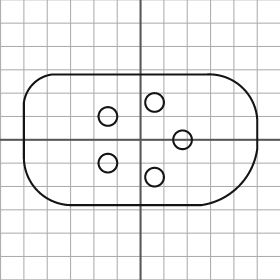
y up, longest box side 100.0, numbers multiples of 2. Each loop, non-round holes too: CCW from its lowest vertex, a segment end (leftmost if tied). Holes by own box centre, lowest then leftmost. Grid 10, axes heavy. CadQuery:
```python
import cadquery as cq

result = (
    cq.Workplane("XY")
    .moveTo(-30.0, -28.0)
    .lineTo(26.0, -28.0)
    .threePointArc((42.0, -20.0), (50.0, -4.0))
    .lineTo(50.0, 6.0)
    .threePointArc((44.0, 22.0), (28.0, 28.0))
    .lineTo(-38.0, 28.0)
    .threePointArc((-46.0, 24.0), (-50.0, 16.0))
    .lineTo(-50.0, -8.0)
    .threePointArc((-44.0, -22.0), (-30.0, -28.0))
    .close()
    .moveTo(6.0, -16.0)
    .circle(4.0)
    .moveTo(-14.0, -10.0)
    .circle(4.0)
    .moveTo(18.0, 0.0)
    .circle(4.0)
    .moveTo(-14.0, 10.0)
    .circle(4.0)
    .moveTo(6.0, 16.0)
    .circle(4.0)
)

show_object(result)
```